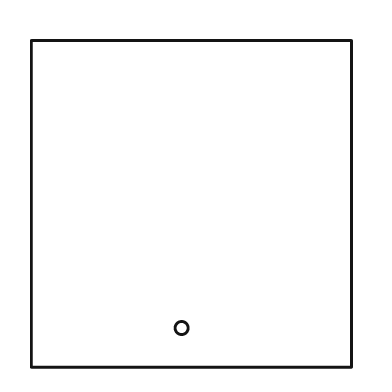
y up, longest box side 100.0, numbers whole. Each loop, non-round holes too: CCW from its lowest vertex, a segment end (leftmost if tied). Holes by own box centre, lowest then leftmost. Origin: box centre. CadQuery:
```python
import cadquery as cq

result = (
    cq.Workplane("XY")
    .moveTo(-49.0, -50.0)
    .lineTo(49.0, -50.0)
    .lineTo(49.0, 50.0)
    .lineTo(-49.0, 50.0)
    .close()
    .moveTo(-3.0, -38.0)
    .circle(2.0)
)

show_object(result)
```